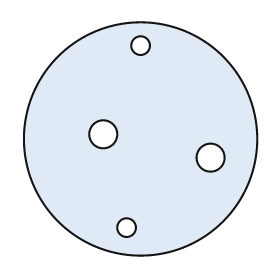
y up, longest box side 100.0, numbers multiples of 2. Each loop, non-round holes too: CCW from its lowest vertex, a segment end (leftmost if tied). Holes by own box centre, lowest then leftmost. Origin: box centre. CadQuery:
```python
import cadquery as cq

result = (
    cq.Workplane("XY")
    .moveTo(0.0, 0.0)
    .circle(50.0)
    .moveTo(-6.0, -38.0)
    .circle(4.0)
    .moveTo(30.0, -8.0)
    .circle(6.0)
    .moveTo(-16.0, 2.0)
    .circle(6.0)
    .moveTo(0.0, 40.0)
    .circle(4.0)
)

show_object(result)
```